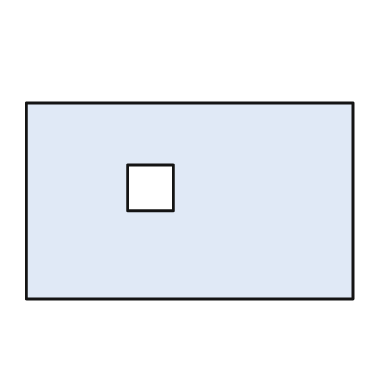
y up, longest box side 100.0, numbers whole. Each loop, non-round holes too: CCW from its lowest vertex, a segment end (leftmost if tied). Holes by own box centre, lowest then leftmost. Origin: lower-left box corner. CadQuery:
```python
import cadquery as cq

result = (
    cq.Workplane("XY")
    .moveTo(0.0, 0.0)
    .lineTo(100.0, 0.0)
    .lineTo(100.0, 60.0)
    .lineTo(0.0, 60.0)
    .close()
    .moveTo(31.0, 27.0)
    .lineTo(45.0, 27.0)
    .lineTo(45.0, 41.0)
    .lineTo(31.0, 41.0)
    .close()
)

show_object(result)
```